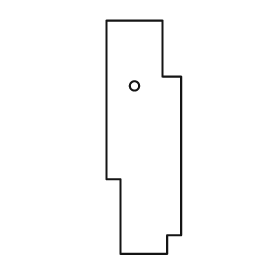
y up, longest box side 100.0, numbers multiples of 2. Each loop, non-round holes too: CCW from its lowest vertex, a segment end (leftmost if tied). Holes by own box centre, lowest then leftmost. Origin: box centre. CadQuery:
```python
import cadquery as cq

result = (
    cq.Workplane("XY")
    .moveTo(-10.0, -50.0)
    .lineTo(10.0, -50.0)
    .lineTo(10.0, -42.0)
    .lineTo(16.0, -42.0)
    .lineTo(16.0, 26.0)
    .lineTo(8.0, 26.0)
    .lineTo(8.0, 50.0)
    .lineTo(-16.0, 50.0)
    .lineTo(-16.0, -18.0)
    .lineTo(-10.0, -18.0)
    .close()
    .moveTo(-4.0, 22.0)
    .circle(2.0)
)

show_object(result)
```